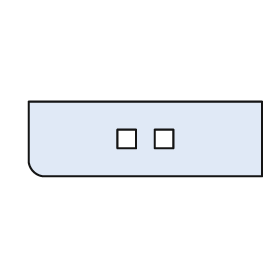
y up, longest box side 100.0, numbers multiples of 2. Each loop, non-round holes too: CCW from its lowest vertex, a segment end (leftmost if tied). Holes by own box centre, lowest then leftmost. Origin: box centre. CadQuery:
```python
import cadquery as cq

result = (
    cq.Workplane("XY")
    .moveTo(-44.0, -16.0)
    .lineTo(50.0, -16.0)
    .lineTo(50.0, 16.0)
    .lineTo(-50.0, 16.0)
    .lineTo(-50.0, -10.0)
    .threePointArc((-48.0, -14.0), (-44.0, -16.0))
    .close()
    .moveTo(-12.0, -4.0)
    .lineTo(-4.0, -4.0)
    .lineTo(-4.0, 4.0)
    .lineTo(-12.0, 4.0)
    .close()
    .moveTo(4.0, -4.0)
    .lineTo(12.0, -4.0)
    .lineTo(12.0, 4.0)
    .lineTo(4.0, 4.0)
    .close()
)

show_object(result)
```